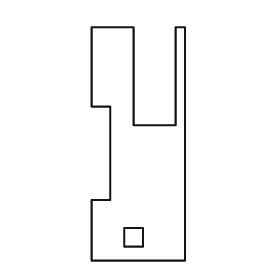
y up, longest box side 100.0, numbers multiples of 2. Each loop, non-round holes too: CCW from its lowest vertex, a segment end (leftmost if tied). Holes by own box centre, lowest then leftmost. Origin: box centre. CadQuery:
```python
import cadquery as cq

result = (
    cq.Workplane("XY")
    .moveTo(-20.0, -50.0)
    .lineTo(20.0, -50.0)
    .lineTo(20.0, 50.0)
    .lineTo(16.0, 50.0)
    .lineTo(16.0, 8.0)
    .lineTo(-2.0, 8.0)
    .lineTo(-2.0, 50.0)
    .lineTo(-20.0, 50.0)
    .lineTo(-20.0, 16.0)
    .lineTo(-12.0, 16.0)
    .lineTo(-12.0, -24.0)
    .lineTo(-20.0, -24.0)
    .close()
    .moveTo(-6.0, -44.0)
    .lineTo(2.0, -44.0)
    .lineTo(2.0, -36.0)
    .lineTo(-6.0, -36.0)
    .close()
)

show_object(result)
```